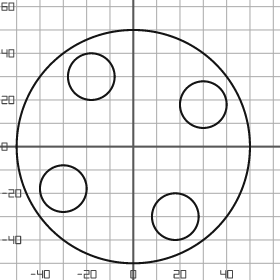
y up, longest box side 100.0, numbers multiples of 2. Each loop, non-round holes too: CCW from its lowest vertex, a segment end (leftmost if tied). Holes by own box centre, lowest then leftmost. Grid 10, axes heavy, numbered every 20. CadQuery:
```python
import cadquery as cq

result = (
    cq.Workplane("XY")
    .moveTo(0.0, 0.0)
    .circle(50.0)
    .moveTo(18.0, -30.0)
    .circle(10.0)
    .moveTo(-30.0, -18.0)
    .circle(10.0)
    .moveTo(30.0, 18.0)
    .circle(10.0)
    .moveTo(-18.0, 30.0)
    .circle(10.0)
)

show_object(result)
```